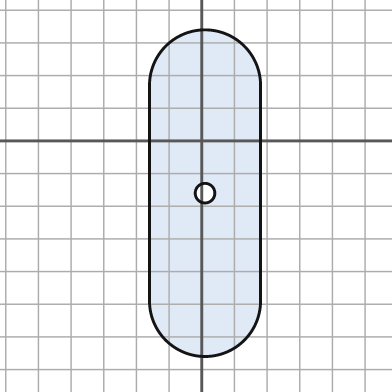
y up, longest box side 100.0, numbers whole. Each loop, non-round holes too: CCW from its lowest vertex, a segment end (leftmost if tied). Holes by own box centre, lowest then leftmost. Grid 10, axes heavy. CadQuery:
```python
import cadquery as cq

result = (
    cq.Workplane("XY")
    .moveTo(-16.0, -49.0)
    .threePointArc((1.0, -66.0), (18.0, -49.0))
    .lineTo(18.0, 17.0)
    .threePointArc((1.0, 34.0), (-16.0, 17.0))
    .close()
    .moveTo(1.0, -16.0)
    .circle(3.0)
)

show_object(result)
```